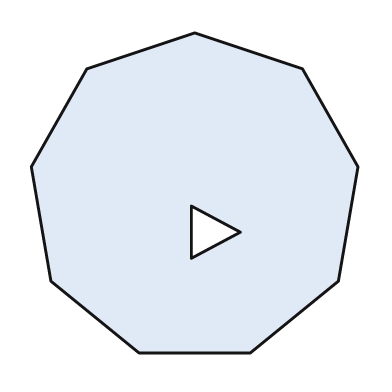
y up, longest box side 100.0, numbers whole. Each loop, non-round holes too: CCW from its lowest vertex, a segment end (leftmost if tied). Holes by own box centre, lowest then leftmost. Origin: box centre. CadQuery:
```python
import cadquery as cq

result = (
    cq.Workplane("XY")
    .moveTo(-17.0, -49.0)
    .lineTo(17.0, -49.0)
    .lineTo(44.0, -27.0)
    .lineTo(50.0, 8.0)
    .lineTo(33.0, 38.0)
    .lineTo(0.0, 49.0)
    .lineTo(-33.0, 38.0)
    .lineTo(-50.0, 8.0)
    .lineTo(-44.0, -27.0)
    .close()
    .moveTo(-1.0, -20.0)
    .lineTo(14.0, -12.0)
    .lineTo(-1.0, -4.0)
    .close()
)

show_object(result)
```